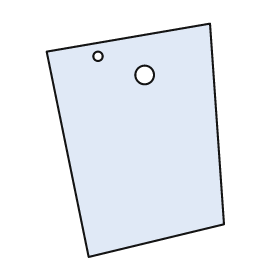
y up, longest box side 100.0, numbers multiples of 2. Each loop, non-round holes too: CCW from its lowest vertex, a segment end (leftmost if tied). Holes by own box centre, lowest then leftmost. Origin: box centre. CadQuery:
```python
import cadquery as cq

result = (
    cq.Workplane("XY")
    .moveTo(-20.0, -50.0)
    .lineTo(38.0, -36.0)
    .lineTo(32.0, 50.0)
    .lineTo(-38.0, 38.0)
    .close()
    .moveTo(4.0, 28.0)
    .circle(4.0)
    .moveTo(-16.0, 36.0)
    .circle(2.0)
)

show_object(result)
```